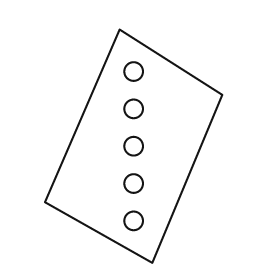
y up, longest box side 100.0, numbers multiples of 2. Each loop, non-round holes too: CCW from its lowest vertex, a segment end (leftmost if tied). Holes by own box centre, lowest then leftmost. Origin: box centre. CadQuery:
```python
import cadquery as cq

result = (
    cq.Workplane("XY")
    .moveTo(8.0, -50.0)
    .lineTo(38.0, 22.0)
    .lineTo(-6.0, 50.0)
    .lineTo(-38.0, -24.0)
    .close()
    .moveTo(0.0, -32.0)
    .circle(4.0)
    .moveTo(0.0, -16.0)
    .circle(4.0)
    .moveTo(0.0, 0.0)
    .circle(4.0)
    .moveTo(0.0, 16.0)
    .circle(4.0)
    .moveTo(0.0, 32.0)
    .circle(4.0)
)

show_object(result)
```